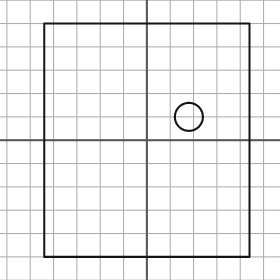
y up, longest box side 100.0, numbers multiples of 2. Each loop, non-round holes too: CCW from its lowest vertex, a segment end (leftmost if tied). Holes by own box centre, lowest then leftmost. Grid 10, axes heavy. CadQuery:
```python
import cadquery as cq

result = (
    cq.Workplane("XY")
    .moveTo(-44.0, -50.0)
    .lineTo(44.0, -50.0)
    .lineTo(44.0, 50.0)
    .lineTo(-44.0, 50.0)
    .close()
    .moveTo(18.0, 10.0)
    .circle(6.0)
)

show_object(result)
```